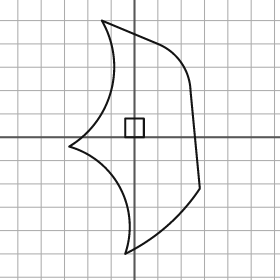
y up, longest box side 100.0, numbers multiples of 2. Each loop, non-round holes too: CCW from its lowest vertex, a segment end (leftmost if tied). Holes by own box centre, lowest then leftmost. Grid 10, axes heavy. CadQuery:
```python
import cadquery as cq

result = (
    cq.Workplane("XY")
    .moveTo(-4.0, -50.0)
    .threePointArc((14.0, -38.0), (28.0, -22.0))
    .lineTo(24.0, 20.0)
    .threePointArc((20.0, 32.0), (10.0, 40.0))
    .lineTo(-14.0, 50.0)
    .threePointArc((-10.0, 20.0), (-28.0, -4.0))
    .threePointArc((-6.0, -22.0), (-4.0, -50.0))
    .close()
    .moveTo(-4.0, 0.0)
    .lineTo(4.0, 0.0)
    .lineTo(4.0, 8.0)
    .lineTo(-4.0, 8.0)
    .close()
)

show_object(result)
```